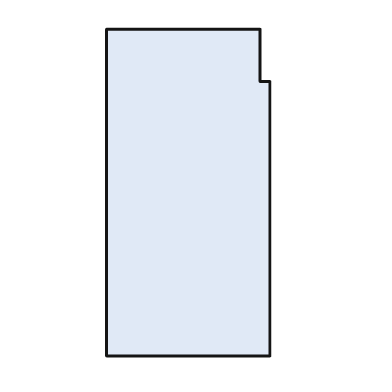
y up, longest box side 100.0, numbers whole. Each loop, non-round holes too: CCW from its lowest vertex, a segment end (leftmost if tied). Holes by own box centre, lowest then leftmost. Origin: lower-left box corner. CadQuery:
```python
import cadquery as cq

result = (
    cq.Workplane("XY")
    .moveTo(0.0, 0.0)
    .lineTo(50.0, 0.0)
    .lineTo(50.0, 84.0)
    .lineTo(47.0, 84.0)
    .lineTo(47.0, 100.0)
    .lineTo(0.0, 100.0)
    .close()
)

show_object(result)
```